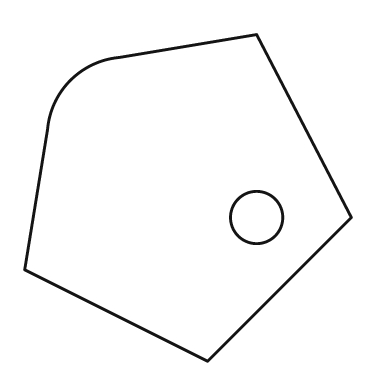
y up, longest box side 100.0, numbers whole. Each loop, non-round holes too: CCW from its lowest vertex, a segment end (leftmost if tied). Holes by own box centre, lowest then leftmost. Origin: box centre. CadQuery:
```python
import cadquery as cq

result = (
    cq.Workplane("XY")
    .moveTo(6.0, -50.0)
    .lineTo(50.0, -6.0)
    .lineTo(21.0, 50.0)
    .lineTo(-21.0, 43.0)
    .threePointArc((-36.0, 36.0), (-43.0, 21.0))
    .lineTo(-50.0, -22.0)
    .close()
    .moveTo(21.0, -6.0)
    .circle(8.0)
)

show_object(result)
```